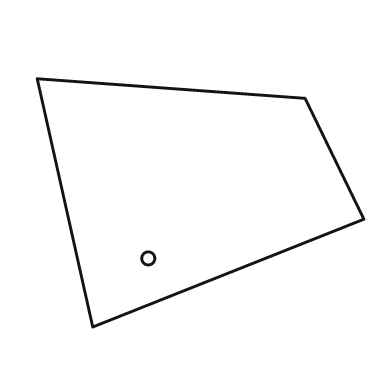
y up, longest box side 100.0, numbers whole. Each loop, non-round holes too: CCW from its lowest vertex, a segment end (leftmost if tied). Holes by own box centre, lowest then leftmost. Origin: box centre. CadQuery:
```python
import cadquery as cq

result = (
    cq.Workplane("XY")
    .moveTo(-33.0, -38.0)
    .lineTo(50.0, -5.0)
    .lineTo(32.0, 32.0)
    .lineTo(-50.0, 38.0)
    .close()
    .moveTo(-16.0, -17.0)
    .circle(2.0)
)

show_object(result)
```